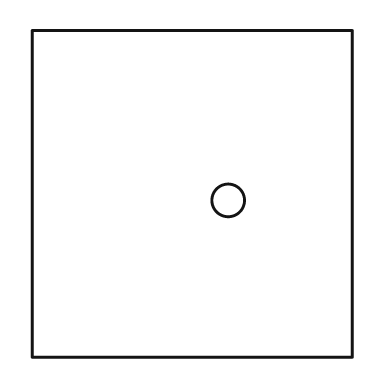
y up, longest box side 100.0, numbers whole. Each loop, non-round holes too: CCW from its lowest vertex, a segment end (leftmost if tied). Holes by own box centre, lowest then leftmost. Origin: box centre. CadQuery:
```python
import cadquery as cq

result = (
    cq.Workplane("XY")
    .moveTo(-49.0, -50.0)
    .lineTo(49.0, -50.0)
    .lineTo(49.0, 50.0)
    .lineTo(-49.0, 50.0)
    .close()
    .moveTo(11.0, -2.0)
    .circle(5.0)
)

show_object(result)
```